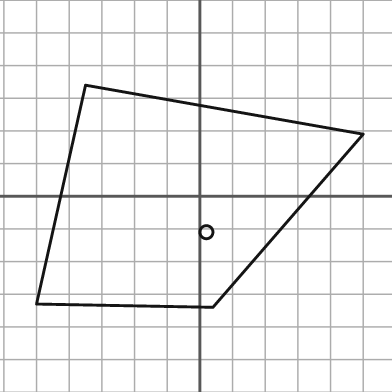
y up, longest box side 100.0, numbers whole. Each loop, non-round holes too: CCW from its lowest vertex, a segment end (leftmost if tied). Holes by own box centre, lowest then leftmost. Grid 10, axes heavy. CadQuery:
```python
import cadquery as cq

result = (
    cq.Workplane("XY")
    .moveTo(4.0, -34.0)
    .lineTo(50.0, 19.0)
    .lineTo(-35.0, 34.0)
    .lineTo(-50.0, -33.0)
    .close()
    .moveTo(2.0, -11.0)
    .circle(2.0)
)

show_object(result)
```